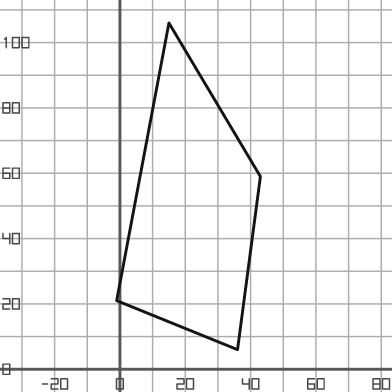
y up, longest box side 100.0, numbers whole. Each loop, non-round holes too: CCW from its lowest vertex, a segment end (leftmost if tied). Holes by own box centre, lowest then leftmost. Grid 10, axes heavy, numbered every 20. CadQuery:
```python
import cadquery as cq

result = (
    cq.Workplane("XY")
    .moveTo(36.0, 6.0)
    .lineTo(43.0, 59.0)
    .lineTo(15.0, 106.0)
    .lineTo(-1.0, 21.0)
    .close()
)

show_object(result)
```